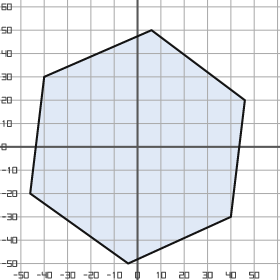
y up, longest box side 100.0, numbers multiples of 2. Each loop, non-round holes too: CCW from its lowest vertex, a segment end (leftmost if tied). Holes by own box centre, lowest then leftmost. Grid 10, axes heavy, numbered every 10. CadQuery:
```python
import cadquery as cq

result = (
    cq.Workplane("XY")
    .moveTo(-4.0, -50.0)
    .lineTo(40.0, -30.0)
    .lineTo(46.0, 20.0)
    .lineTo(6.0, 50.0)
    .lineTo(-40.0, 30.0)
    .lineTo(-46.0, -20.0)
    .close()
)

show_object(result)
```